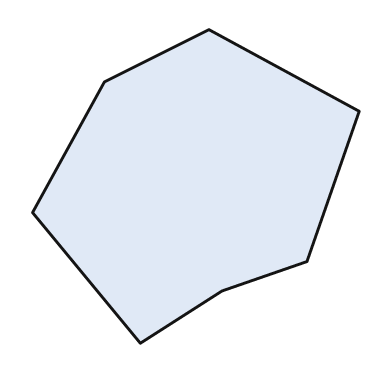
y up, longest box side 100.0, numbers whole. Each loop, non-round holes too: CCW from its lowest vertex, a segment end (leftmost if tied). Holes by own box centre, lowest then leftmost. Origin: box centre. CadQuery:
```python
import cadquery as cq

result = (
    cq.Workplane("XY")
    .moveTo(-17.0, -48.0)
    .lineTo(8.0, -32.0)
    .lineTo(34.0, -23.0)
    .lineTo(50.0, 23.0)
    .lineTo(4.0, 48.0)
    .lineTo(-28.0, 32.0)
    .lineTo(-50.0, -8.0)
    .close()
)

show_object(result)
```